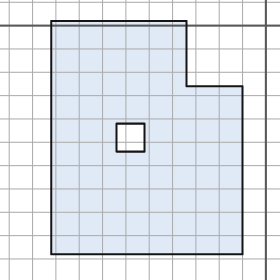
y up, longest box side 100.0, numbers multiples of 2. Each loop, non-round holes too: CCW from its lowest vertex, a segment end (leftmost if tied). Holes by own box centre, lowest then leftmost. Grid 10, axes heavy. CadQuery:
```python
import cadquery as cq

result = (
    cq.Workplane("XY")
    .moveTo(-92.0, -98.0)
    .lineTo(-10.0, -98.0)
    .lineTo(-10.0, -26.0)
    .lineTo(-34.0, -26.0)
    .lineTo(-34.0, 2.0)
    .lineTo(-92.0, 2.0)
    .close()
    .moveTo(-64.0, -54.0)
    .lineTo(-52.0, -54.0)
    .lineTo(-52.0, -42.0)
    .lineTo(-64.0, -42.0)
    .close()
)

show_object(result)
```